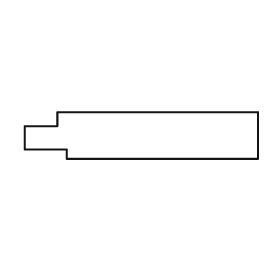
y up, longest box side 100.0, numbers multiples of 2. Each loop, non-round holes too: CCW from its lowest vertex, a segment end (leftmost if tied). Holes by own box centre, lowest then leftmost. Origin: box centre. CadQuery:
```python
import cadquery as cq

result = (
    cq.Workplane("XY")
    .moveTo(-32.0, -10.0)
    .lineTo(50.0, -10.0)
    .lineTo(50.0, 10.0)
    .lineTo(-36.0, 10.0)
    .lineTo(-36.0, 4.0)
    .lineTo(-50.0, 4.0)
    .lineTo(-50.0, -6.0)
    .lineTo(-32.0, -6.0)
    .close()
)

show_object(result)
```